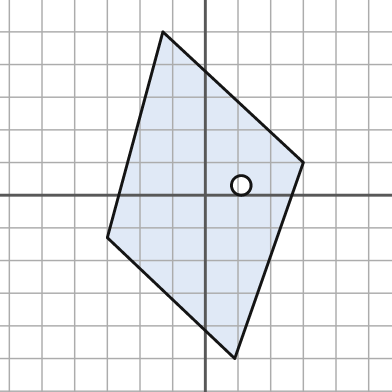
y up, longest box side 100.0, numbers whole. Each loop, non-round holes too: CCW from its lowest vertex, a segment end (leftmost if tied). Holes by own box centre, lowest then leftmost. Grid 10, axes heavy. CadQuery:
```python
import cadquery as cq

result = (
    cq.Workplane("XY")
    .moveTo(9.0, -50.0)
    .lineTo(30.0, 10.0)
    .lineTo(-13.0, 50.0)
    .lineTo(-30.0, -13.0)
    .close()
    .moveTo(11.0, 3.0)
    .circle(3.0)
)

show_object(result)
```